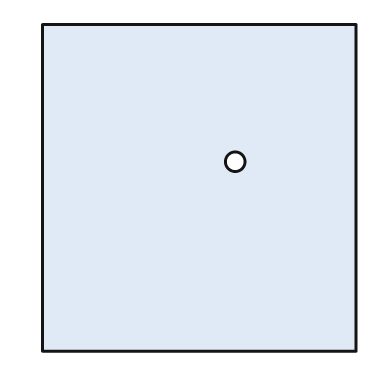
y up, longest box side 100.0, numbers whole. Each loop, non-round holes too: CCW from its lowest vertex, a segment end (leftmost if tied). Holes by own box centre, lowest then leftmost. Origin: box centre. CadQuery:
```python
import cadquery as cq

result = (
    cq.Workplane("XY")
    .moveTo(-48.0, -50.0)
    .lineTo(48.0, -50.0)
    .lineTo(48.0, 50.0)
    .lineTo(-48.0, 50.0)
    .close()
    .moveTo(11.0, 8.0)
    .circle(3.0)
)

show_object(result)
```